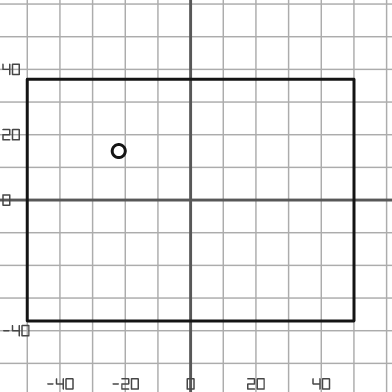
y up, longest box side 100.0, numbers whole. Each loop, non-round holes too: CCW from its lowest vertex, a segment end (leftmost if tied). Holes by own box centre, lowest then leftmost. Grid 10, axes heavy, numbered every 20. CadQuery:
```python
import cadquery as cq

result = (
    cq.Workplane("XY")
    .moveTo(-50.0, -37.0)
    .lineTo(50.0, -37.0)
    .lineTo(50.0, 37.0)
    .lineTo(-50.0, 37.0)
    .close()
    .moveTo(-22.0, 15.0)
    .circle(2.0)
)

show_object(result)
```